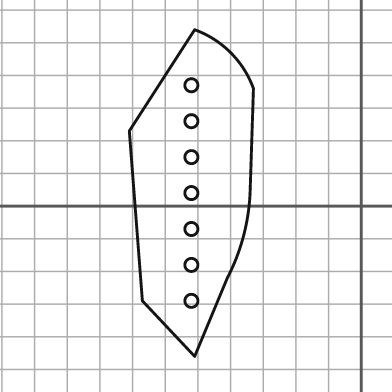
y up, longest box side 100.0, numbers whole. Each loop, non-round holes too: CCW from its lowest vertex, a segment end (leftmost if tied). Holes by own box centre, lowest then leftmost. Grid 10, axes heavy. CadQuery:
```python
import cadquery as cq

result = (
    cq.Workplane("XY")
    .moveTo(-51.0, -46.0)
    .lineTo(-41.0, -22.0)
    .threePointArc((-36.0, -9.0), (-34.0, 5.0))
    .lineTo(-33.0, 36.0)
    .threePointArc((-40.0, 47.0), (-51.0, 54.0))
    .lineTo(-71.0, 23.0)
    .lineTo(-67.0, -29.0)
    .close()
    .moveTo(-52.0, -29.0)
    .circle(2.0)
    .moveTo(-52.0, -18.0)
    .circle(2.0)
    .moveTo(-52.0, -7.0)
    .circle(2.0)
    .moveTo(-52.0, 4.0)
    .circle(2.0)
    .moveTo(-52.0, 15.0)
    .circle(2.0)
    .moveTo(-52.0, 26.0)
    .circle(2.0)
    .moveTo(-52.0, 37.0)
    .circle(2.0)
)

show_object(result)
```